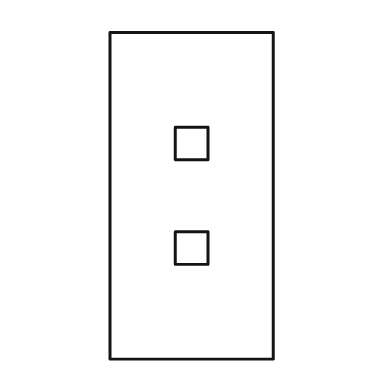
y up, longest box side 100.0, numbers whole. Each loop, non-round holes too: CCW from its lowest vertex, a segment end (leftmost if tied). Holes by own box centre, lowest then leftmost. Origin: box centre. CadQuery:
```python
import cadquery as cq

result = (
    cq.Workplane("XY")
    .moveTo(-25.0, -50.0)
    .lineTo(25.0, -50.0)
    .lineTo(25.0, 50.0)
    .lineTo(-25.0, 50.0)
    .close()
    .moveTo(-5.0, -21.0)
    .lineTo(5.0, -21.0)
    .lineTo(5.0, -11.0)
    .lineTo(-5.0, -11.0)
    .close()
    .moveTo(-5.0, 11.0)
    .lineTo(5.0, 11.0)
    .lineTo(5.0, 21.0)
    .lineTo(-5.0, 21.0)
    .close()
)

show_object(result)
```